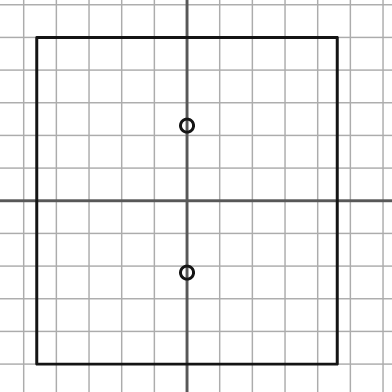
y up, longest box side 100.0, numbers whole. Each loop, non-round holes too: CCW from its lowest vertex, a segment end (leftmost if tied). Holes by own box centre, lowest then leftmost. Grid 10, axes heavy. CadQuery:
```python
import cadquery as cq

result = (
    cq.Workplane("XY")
    .moveTo(-46.0, -50.0)
    .lineTo(46.0, -50.0)
    .lineTo(46.0, 50.0)
    .lineTo(-46.0, 50.0)
    .close()
    .moveTo(0.0, -22.0)
    .circle(2.0)
    .moveTo(0.0, 23.0)
    .circle(2.0)
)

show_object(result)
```